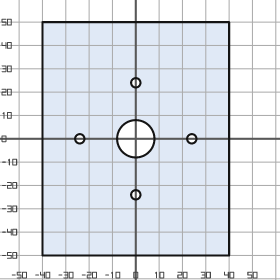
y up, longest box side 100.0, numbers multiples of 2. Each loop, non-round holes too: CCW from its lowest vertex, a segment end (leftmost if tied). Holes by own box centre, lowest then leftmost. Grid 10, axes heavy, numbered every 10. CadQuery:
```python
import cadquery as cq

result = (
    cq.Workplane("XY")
    .moveTo(-40.0, -50.0)
    .lineTo(40.0, -50.0)
    .lineTo(40.0, 50.0)
    .lineTo(-40.0, 50.0)
    .close()
    .moveTo(0.0, -24.0)
    .circle(2.0)
    .moveTo(-24.0, 0.0)
    .circle(2.0)
    .moveTo(0.0, 0.0)
    .circle(8.0)
    .moveTo(24.0, 0.0)
    .circle(2.0)
    .moveTo(0.0, 24.0)
    .circle(2.0)
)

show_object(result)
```